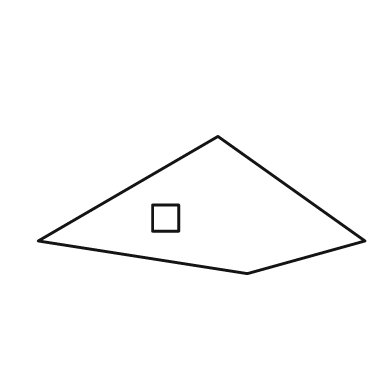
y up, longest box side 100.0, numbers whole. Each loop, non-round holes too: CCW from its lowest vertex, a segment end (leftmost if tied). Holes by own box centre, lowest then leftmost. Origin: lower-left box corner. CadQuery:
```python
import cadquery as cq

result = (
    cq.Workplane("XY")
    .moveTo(64.0, 0.0)
    .lineTo(100.0, 10.0)
    .lineTo(55.0, 42.0)
    .lineTo(0.0, 10.0)
    .close()
    .moveTo(35.0, 13.0)
    .lineTo(43.0, 13.0)
    .lineTo(43.0, 21.0)
    .lineTo(35.0, 21.0)
    .close()
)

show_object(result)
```